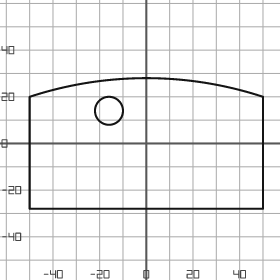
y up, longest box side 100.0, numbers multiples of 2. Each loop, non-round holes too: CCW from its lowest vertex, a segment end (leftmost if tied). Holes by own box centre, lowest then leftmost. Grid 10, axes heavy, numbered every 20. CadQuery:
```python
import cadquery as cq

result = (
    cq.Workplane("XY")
    .moveTo(-50.0, -28.0)
    .lineTo(50.0, -28.0)
    .lineTo(50.0, 20.0)
    .threePointArc((0.0, 28.0), (-50.0, 20.0))
    .close()
    .moveTo(-16.0, 14.0)
    .circle(6.0)
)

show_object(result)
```